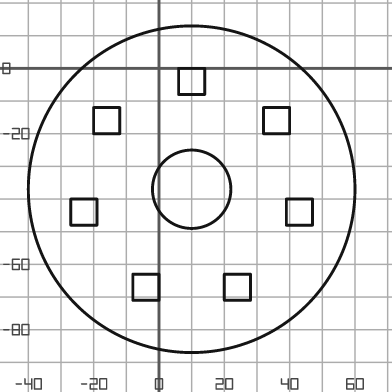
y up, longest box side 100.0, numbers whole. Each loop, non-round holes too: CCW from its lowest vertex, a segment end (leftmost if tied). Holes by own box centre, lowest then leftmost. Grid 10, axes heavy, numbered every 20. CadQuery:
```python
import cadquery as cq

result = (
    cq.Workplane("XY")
    .moveTo(10.0, -37.0)
    .circle(50.0)
    .moveTo(-8.0, -71.0)
    .lineTo(0.0, -71.0)
    .lineTo(0.0, -63.0)
    .lineTo(-8.0, -63.0)
    .close()
    .moveTo(20.0, -71.0)
    .lineTo(28.0, -71.0)
    .lineTo(28.0, -63.0)
    .lineTo(20.0, -63.0)
    .close()
    .moveTo(-27.0, -48.0)
    .lineTo(-19.0, -48.0)
    .lineTo(-19.0, -40.0)
    .lineTo(-27.0, -40.0)
    .close()
    .moveTo(39.0, -48.0)
    .lineTo(47.0, -48.0)
    .lineTo(47.0, -40.0)
    .lineTo(39.0, -40.0)
    .close()
    .moveTo(10.0, -37.0)
    .circle(12.0)
    .moveTo(-20.0, -20.0)
    .lineTo(-12.0, -20.0)
    .lineTo(-12.0, -12.0)
    .lineTo(-20.0, -12.0)
    .close()
    .moveTo(32.0, -20.0)
    .lineTo(40.0, -20.0)
    .lineTo(40.0, -12.0)
    .lineTo(32.0, -12.0)
    .close()
    .moveTo(6.0, -8.0)
    .lineTo(14.0, -8.0)
    .lineTo(14.0, 0.0)
    .lineTo(6.0, 0.0)
    .close()
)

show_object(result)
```